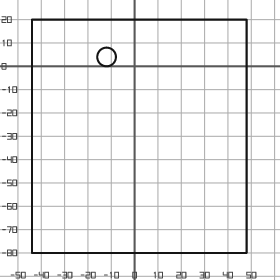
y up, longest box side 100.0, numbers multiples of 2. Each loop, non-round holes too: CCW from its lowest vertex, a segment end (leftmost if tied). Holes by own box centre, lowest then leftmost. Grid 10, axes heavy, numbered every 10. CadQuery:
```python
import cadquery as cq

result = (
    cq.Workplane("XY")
    .moveTo(-44.0, -80.0)
    .lineTo(48.0, -80.0)
    .lineTo(48.0, 20.0)
    .lineTo(-44.0, 20.0)
    .close()
    .moveTo(-12.0, 4.0)
    .circle(4.0)
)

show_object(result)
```